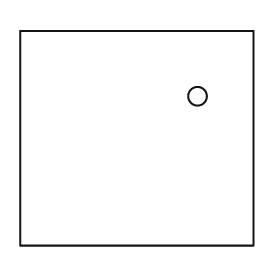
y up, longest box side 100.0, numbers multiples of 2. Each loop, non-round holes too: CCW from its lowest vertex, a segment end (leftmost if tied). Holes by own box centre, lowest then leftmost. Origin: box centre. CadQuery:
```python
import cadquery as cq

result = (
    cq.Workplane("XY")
    .moveTo(-50.0, -46.0)
    .lineTo(50.0, -46.0)
    .lineTo(50.0, 46.0)
    .lineTo(-50.0, 46.0)
    .close()
    .moveTo(26.0, 18.0)
    .circle(4.0)
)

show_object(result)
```